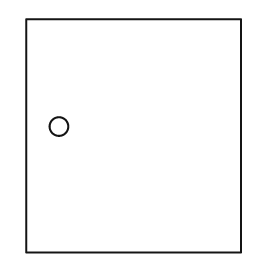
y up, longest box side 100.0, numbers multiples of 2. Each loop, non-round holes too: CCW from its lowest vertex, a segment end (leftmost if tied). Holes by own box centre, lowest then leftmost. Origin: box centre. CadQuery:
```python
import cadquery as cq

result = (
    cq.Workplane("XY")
    .moveTo(-46.0, -50.0)
    .lineTo(46.0, -50.0)
    .lineTo(46.0, 50.0)
    .lineTo(-46.0, 50.0)
    .close()
    .moveTo(-32.0, 4.0)
    .circle(4.0)
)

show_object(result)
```